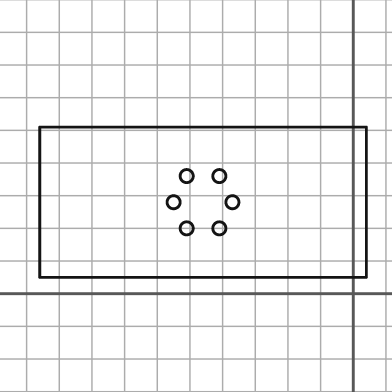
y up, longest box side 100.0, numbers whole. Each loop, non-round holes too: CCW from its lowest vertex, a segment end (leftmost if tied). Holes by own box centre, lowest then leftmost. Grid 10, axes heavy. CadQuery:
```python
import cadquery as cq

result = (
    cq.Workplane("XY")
    .moveTo(-96.0, 5.0)
    .lineTo(4.0, 5.0)
    .lineTo(4.0, 51.0)
    .lineTo(-96.0, 51.0)
    .close()
    .moveTo(-51.0, 20.0)
    .circle(2.0)
    .moveTo(-41.0, 20.0)
    .circle(2.0)
    .moveTo(-55.0, 28.0)
    .circle(2.0)
    .moveTo(-37.0, 28.0)
    .circle(2.0)
    .moveTo(-51.0, 36.0)
    .circle(2.0)
    .moveTo(-41.0, 36.0)
    .circle(2.0)
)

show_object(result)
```